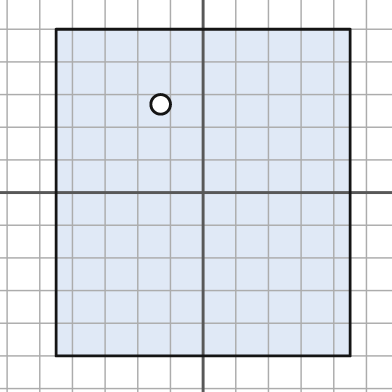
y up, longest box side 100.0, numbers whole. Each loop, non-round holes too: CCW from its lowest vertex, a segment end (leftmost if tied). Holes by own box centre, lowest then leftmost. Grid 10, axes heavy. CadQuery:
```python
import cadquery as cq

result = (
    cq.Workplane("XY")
    .moveTo(-45.0, -50.0)
    .lineTo(45.0, -50.0)
    .lineTo(45.0, 50.0)
    .lineTo(-45.0, 50.0)
    .close()
    .moveTo(-13.0, 27.0)
    .circle(3.0)
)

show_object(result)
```